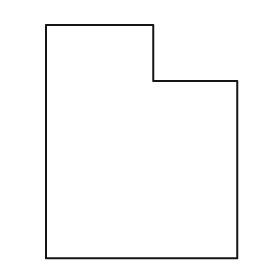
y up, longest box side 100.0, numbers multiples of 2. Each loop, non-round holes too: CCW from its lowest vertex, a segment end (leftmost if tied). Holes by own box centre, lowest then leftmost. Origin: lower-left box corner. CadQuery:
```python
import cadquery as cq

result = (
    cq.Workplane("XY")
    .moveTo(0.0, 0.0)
    .lineTo(82.0, 0.0)
    .lineTo(82.0, 76.0)
    .lineTo(46.0, 76.0)
    .lineTo(46.0, 100.0)
    .lineTo(0.0, 100.0)
    .close()
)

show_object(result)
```